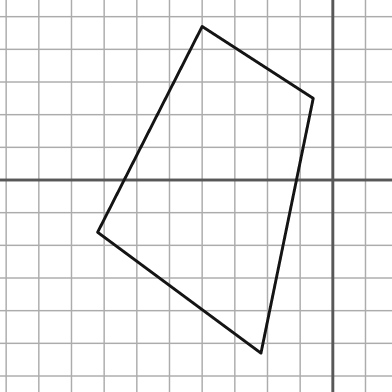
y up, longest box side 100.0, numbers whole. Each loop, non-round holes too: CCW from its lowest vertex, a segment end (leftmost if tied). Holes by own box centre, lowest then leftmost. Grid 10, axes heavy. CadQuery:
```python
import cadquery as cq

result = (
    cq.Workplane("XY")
    .moveTo(-22.0, -53.0)
    .lineTo(-6.0, 25.0)
    .lineTo(-40.0, 47.0)
    .lineTo(-72.0, -16.0)
    .close()
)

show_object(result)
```